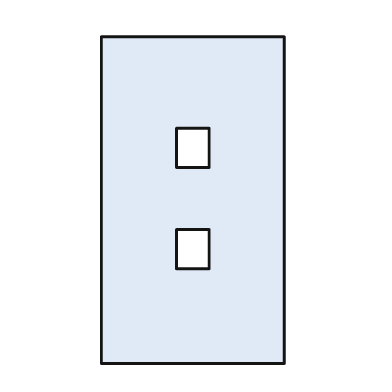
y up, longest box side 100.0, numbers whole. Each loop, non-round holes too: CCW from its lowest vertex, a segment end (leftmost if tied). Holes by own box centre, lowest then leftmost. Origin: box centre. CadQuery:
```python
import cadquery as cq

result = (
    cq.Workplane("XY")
    .moveTo(-28.0, -50.0)
    .lineTo(28.0, -50.0)
    .lineTo(28.0, 50.0)
    .lineTo(-28.0, 50.0)
    .close()
    .moveTo(-5.0, -21.0)
    .lineTo(5.0, -21.0)
    .lineTo(5.0, -9.0)
    .lineTo(-5.0, -9.0)
    .close()
    .moveTo(-5.0, 10.0)
    .lineTo(5.0, 10.0)
    .lineTo(5.0, 22.0)
    .lineTo(-5.0, 22.0)
    .close()
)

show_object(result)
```